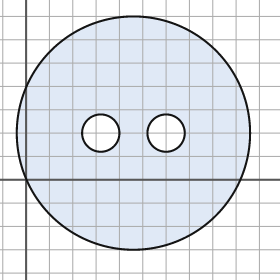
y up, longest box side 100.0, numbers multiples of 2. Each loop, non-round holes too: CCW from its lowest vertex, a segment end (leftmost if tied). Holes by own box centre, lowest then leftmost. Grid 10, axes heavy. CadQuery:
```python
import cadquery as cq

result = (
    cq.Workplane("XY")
    .moveTo(46.0, 20.0)
    .circle(50.0)
    .moveTo(32.0, 20.0)
    .circle(8.0)
    .moveTo(60.0, 20.0)
    .circle(8.0)
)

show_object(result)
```